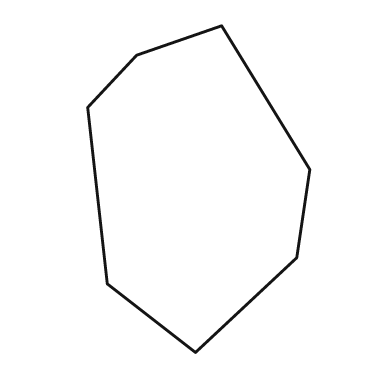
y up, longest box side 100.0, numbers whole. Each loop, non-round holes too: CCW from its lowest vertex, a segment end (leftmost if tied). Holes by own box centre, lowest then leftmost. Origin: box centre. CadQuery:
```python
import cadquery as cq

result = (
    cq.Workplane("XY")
    .moveTo(-1.0, -50.0)
    .lineTo(30.0, -21.0)
    .lineTo(34.0, 6.0)
    .lineTo(7.0, 50.0)
    .lineTo(-19.0, 41.0)
    .lineTo(-34.0, 25.0)
    .lineTo(-28.0, -29.0)
    .close()
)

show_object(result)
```